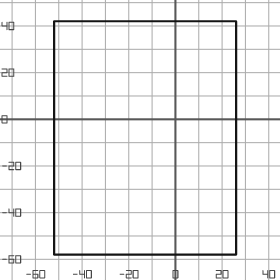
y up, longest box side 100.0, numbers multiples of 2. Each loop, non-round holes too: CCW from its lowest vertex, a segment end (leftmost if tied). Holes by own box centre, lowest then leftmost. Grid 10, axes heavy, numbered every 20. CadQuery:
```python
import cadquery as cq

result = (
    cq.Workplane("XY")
    .moveTo(-52.0, -58.0)
    .lineTo(26.0, -58.0)
    .lineTo(26.0, 42.0)
    .lineTo(-52.0, 42.0)
    .close()
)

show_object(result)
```